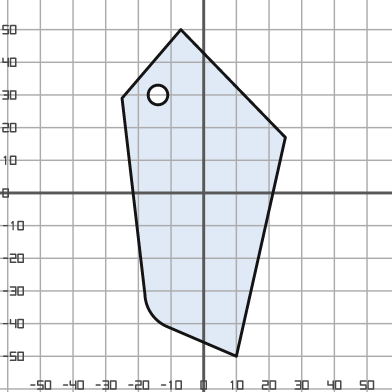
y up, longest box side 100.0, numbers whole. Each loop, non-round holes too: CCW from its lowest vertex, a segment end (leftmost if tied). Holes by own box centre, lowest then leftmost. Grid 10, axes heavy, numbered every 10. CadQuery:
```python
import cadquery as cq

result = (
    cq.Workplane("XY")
    .moveTo(10.0, -50.0)
    .lineTo(25.0, 17.0)
    .lineTo(-7.0, 50.0)
    .lineTo(-25.0, 29.0)
    .lineTo(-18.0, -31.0)
    .threePointArc((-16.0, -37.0), (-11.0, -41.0))
    .close()
    .moveTo(-14.0, 30.0)
    .circle(3.0)
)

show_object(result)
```